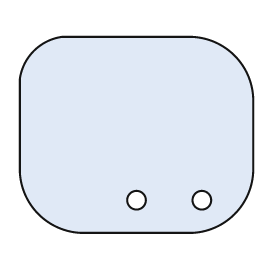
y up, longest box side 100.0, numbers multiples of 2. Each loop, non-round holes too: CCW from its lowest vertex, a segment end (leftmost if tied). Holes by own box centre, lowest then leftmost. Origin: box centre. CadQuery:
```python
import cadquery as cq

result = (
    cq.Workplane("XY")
    .moveTo(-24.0, -42.0)
    .lineTo(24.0, -42.0)
    .threePointArc((42.0, -34.0), (50.0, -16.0))
    .lineTo(50.0, 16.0)
    .threePointArc((42.0, 34.0), (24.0, 42.0))
    .lineTo(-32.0, 42.0)
    .threePointArc((-44.0, 36.0), (-50.0, 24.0))
    .lineTo(-50.0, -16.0)
    .threePointArc((-42.0, -34.0), (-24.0, -42.0))
    .close()
    .moveTo(0.0, -28.0)
    .circle(4.0)
    .moveTo(28.0, -28.0)
    .circle(4.0)
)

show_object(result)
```